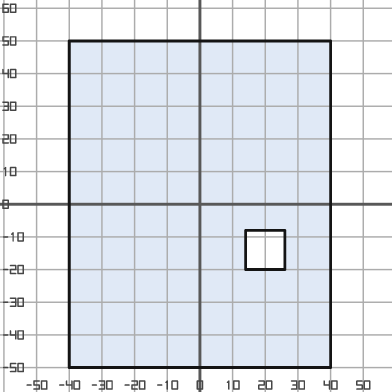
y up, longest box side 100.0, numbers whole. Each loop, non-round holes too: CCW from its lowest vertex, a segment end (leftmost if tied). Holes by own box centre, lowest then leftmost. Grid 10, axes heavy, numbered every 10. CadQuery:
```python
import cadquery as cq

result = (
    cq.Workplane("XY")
    .moveTo(-40.0, -50.0)
    .lineTo(40.0, -50.0)
    .lineTo(40.0, 50.0)
    .lineTo(-40.0, 50.0)
    .close()
    .moveTo(14.0, -20.0)
    .lineTo(26.0, -20.0)
    .lineTo(26.0, -8.0)
    .lineTo(14.0, -8.0)
    .close()
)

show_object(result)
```